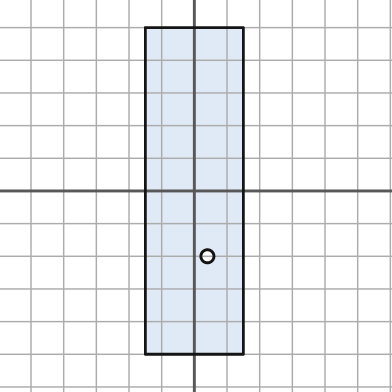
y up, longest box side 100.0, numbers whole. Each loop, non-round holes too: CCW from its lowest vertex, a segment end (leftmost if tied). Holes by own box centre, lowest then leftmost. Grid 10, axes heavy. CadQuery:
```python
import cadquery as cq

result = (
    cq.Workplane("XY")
    .moveTo(-15.0, -50.0)
    .lineTo(15.0, -50.0)
    .lineTo(15.0, 50.0)
    .lineTo(-15.0, 50.0)
    .close()
    .moveTo(4.0, -20.0)
    .circle(2.0)
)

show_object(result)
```